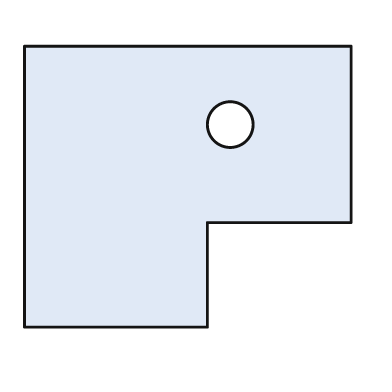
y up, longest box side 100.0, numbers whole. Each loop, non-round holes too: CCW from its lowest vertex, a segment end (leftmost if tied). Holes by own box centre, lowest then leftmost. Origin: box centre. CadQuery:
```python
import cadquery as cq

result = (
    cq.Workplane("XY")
    .moveTo(-50.0, -43.0)
    .lineTo(6.0, -43.0)
    .lineTo(6.0, -11.0)
    .lineTo(50.0, -11.0)
    .lineTo(50.0, 43.0)
    .lineTo(-50.0, 43.0)
    .close()
    .moveTo(13.0, 19.0)
    .circle(7.0)
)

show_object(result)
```